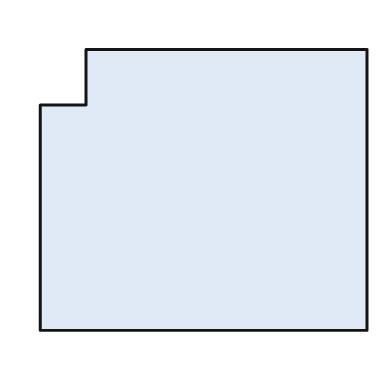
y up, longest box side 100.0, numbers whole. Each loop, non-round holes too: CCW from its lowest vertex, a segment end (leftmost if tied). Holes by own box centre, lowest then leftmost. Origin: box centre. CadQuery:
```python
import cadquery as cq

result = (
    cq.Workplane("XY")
    .moveTo(-50.0, -43.0)
    .lineTo(50.0, -43.0)
    .lineTo(50.0, 43.0)
    .lineTo(-36.0, 43.0)
    .lineTo(-36.0, 26.0)
    .lineTo(-50.0, 26.0)
    .close()
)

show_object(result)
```